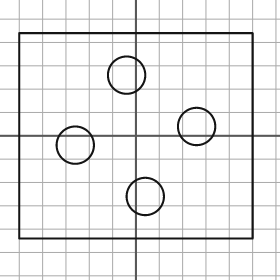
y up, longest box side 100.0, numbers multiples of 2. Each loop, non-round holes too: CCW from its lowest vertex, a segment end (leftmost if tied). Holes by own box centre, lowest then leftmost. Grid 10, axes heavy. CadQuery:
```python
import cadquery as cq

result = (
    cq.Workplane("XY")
    .moveTo(-50.0, -44.0)
    .lineTo(50.0, -44.0)
    .lineTo(50.0, 44.0)
    .lineTo(-50.0, 44.0)
    .close()
    .moveTo(4.0, -26.0)
    .circle(8.0)
    .moveTo(-26.0, -4.0)
    .circle(8.0)
    .moveTo(26.0, 4.0)
    .circle(8.0)
    .moveTo(-4.0, 26.0)
    .circle(8.0)
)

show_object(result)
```